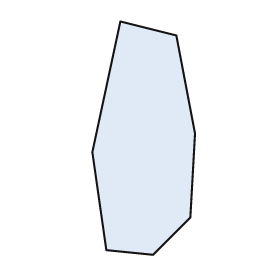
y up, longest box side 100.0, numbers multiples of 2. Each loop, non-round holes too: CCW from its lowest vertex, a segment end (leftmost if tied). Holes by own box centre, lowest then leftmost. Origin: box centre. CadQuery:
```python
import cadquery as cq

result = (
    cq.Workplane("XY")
    .moveTo(4.0, -50.0)
    .lineTo(20.0, -34.0)
    .lineTo(22.0, 2.0)
    .lineTo(14.0, 44.0)
    .lineTo(-10.0, 50.0)
    .lineTo(-22.0, -6.0)
    .lineTo(-16.0, -48.0)
    .close()
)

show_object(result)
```